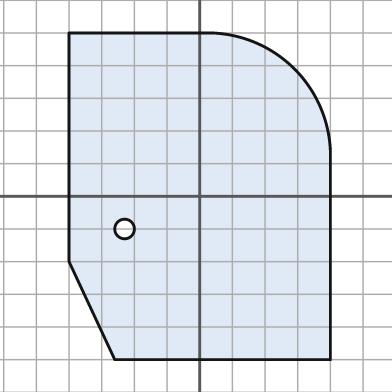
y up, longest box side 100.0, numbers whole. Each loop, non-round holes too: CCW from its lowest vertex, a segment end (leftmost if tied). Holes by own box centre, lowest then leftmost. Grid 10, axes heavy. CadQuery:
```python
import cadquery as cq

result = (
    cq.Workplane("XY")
    .moveTo(-26.0, -50.0)
    .lineTo(40.0, -50.0)
    .lineTo(40.0, 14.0)
    .threePointArc((29.0, 39.0), (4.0, 50.0))
    .lineTo(-40.0, 50.0)
    .lineTo(-40.0, -20.0)
    .close()
    .moveTo(-23.0, -10.0)
    .circle(3.0)
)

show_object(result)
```